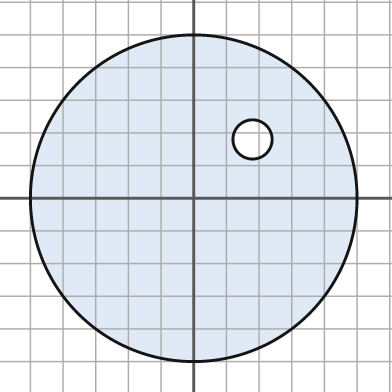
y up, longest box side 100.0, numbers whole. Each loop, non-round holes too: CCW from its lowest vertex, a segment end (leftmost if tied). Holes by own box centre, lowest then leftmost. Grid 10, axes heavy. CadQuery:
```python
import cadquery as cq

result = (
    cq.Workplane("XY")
    .moveTo(0.0, 0.0)
    .circle(50.0)
    .moveTo(18.0, 18.0)
    .circle(6.0)
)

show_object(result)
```